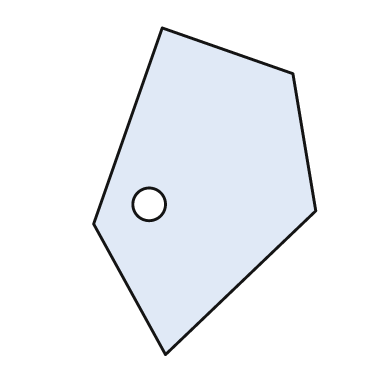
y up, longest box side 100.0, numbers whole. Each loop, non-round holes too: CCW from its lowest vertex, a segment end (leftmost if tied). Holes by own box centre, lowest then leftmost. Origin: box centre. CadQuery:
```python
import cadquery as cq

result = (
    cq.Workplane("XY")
    .moveTo(-12.0, -50.0)
    .lineTo(34.0, -6.0)
    .lineTo(27.0, 36.0)
    .lineTo(-13.0, 50.0)
    .lineTo(-34.0, -10.0)
    .close()
    .moveTo(-17.0, -4.0)
    .circle(5.0)
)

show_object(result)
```